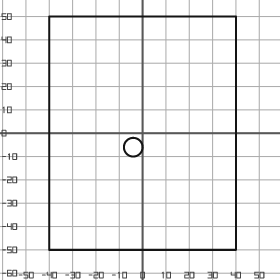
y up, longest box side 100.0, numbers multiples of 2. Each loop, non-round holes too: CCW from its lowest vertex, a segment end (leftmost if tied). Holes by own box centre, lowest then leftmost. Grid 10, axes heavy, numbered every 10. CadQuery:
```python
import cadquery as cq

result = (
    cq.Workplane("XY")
    .moveTo(-40.0, -50.0)
    .lineTo(40.0, -50.0)
    .lineTo(40.0, 50.0)
    .lineTo(-40.0, 50.0)
    .close()
    .moveTo(-4.0, -6.0)
    .circle(4.0)
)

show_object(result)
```